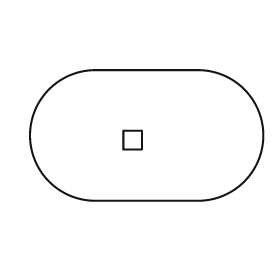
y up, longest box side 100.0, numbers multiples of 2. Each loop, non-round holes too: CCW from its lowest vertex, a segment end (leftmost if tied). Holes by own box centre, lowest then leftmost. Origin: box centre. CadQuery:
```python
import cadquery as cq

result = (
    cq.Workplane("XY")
    .moveTo(-22.0, -28.0)
    .lineTo(22.0, -28.0)
    .threePointArc((50.0, 0.0), (22.0, 28.0))
    .lineTo(-22.0, 28.0)
    .threePointArc((-50.0, 0.0), (-22.0, -28.0))
    .close()
    .moveTo(-10.0, -6.0)
    .lineTo(-2.0, -6.0)
    .lineTo(-2.0, 2.0)
    .lineTo(-10.0, 2.0)
    .close()
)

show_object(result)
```